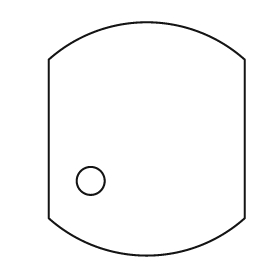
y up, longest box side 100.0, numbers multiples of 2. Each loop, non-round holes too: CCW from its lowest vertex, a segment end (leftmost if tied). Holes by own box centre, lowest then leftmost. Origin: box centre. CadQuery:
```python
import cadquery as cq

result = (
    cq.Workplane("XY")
    .moveTo(-42.0, -34.0)
    .threePointArc((0.0, -50.0), (42.0, -34.0))
    .lineTo(42.0, 34.0)
    .threePointArc((0.0, 50.0), (-42.0, 34.0))
    .close()
    .moveTo(-24.0, -18.0)
    .circle(6.0)
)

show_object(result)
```